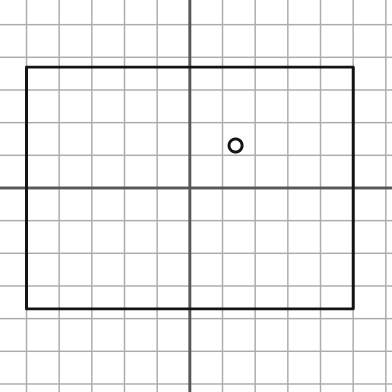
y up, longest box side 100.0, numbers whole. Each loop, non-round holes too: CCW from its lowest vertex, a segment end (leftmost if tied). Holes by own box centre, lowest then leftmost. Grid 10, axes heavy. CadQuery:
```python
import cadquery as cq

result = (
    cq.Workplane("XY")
    .moveTo(-50.0, -37.0)
    .lineTo(50.0, -37.0)
    .lineTo(50.0, 37.0)
    .lineTo(-50.0, 37.0)
    .close()
    .moveTo(14.0, 13.0)
    .circle(2.0)
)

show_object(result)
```